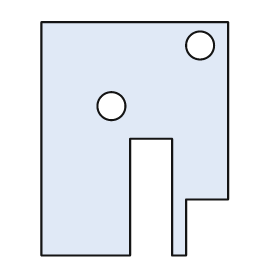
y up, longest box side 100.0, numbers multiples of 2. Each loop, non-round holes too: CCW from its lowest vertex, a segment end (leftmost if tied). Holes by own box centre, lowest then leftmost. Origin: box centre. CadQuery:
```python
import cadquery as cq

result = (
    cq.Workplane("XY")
    .moveTo(-40.0, -50.0)
    .lineTo(-2.0, -50.0)
    .lineTo(-2.0, 0.0)
    .lineTo(16.0, 0.0)
    .lineTo(16.0, -50.0)
    .lineTo(22.0, -50.0)
    .lineTo(22.0, -26.0)
    .lineTo(40.0, -26.0)
    .lineTo(40.0, 50.0)
    .lineTo(-40.0, 50.0)
    .close()
    .moveTo(-10.0, 14.0)
    .circle(6.0)
    .moveTo(28.0, 40.0)
    .circle(6.0)
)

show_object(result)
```